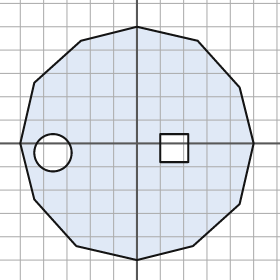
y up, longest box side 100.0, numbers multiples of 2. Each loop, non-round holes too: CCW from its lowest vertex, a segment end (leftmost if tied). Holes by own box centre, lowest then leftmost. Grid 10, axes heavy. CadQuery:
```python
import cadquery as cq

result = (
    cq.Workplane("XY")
    .moveTo(0.0, -50.0)
    .lineTo(24.0, -44.0)
    .lineTo(44.0, -26.0)
    .lineTo(50.0, 0.0)
    .lineTo(44.0, 24.0)
    .lineTo(26.0, 44.0)
    .lineTo(0.0, 50.0)
    .lineTo(-24.0, 44.0)
    .lineTo(-44.0, 26.0)
    .lineTo(-50.0, 0.0)
    .lineTo(-44.0, -24.0)
    .lineTo(-26.0, -44.0)
    .close()
    .moveTo(-36.0, -4.0)
    .circle(8.0)
    .moveTo(10.0, -8.0)
    .lineTo(22.0, -8.0)
    .lineTo(22.0, 4.0)
    .lineTo(10.0, 4.0)
    .close()
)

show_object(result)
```